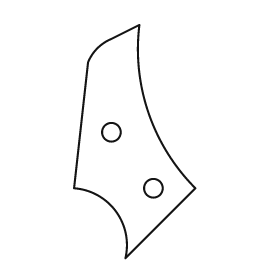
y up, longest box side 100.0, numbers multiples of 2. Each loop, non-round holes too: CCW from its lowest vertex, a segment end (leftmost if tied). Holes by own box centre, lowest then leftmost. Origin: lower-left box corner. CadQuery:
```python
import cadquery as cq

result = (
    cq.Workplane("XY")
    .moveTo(22.0, 0.0)
    .lineTo(52.0, 30.0)
    .threePointArc((32.0, 62.0), (28.0, 100.0))
    .lineTo(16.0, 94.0)
    .threePointArc((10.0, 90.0), (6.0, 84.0))
    .lineTo(0.0, 30.0)
    .threePointArc((18.0, 20.0), (22.0, 0.0))
    .close()
    .moveTo(34.0, 30.0)
    .circle(4.0)
    .moveTo(16.0, 54.0)
    .circle(4.0)
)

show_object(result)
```